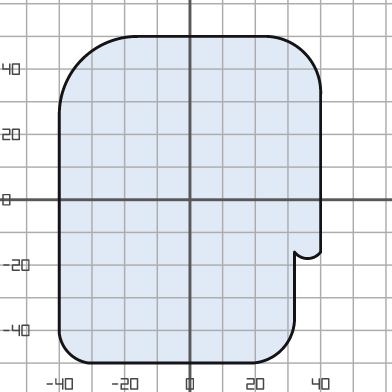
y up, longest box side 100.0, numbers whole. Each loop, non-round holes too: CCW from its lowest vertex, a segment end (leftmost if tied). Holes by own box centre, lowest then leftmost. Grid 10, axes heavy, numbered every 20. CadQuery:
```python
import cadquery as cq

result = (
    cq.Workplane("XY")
    .moveTo(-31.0, -50.0)
    .lineTo(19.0, -50.0)
    .threePointArc((28.0, -46.0), (32.0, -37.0))
    .lineTo(32.0, -16.0)
    .threePointArc((36.0, -18.0), (40.0, -16.0))
    .lineTo(40.0, 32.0)
    .threePointArc((35.0, 45.0), (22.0, 50.0))
    .lineTo(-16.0, 50.0)
    .threePointArc((-33.0, 43.0), (-40.0, 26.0))
    .lineTo(-40.0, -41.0)
    .threePointArc((-37.0, -47.0), (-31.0, -50.0))
    .close()
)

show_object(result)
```